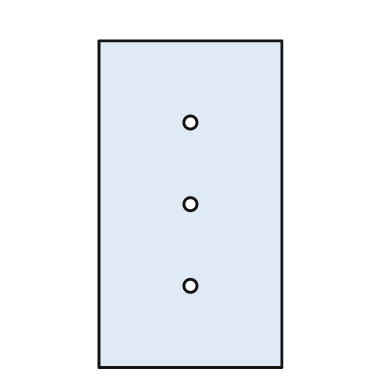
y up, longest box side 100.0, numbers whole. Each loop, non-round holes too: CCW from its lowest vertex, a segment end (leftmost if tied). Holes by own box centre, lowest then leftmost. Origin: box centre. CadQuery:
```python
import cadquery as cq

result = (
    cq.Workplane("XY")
    .moveTo(-28.0, -50.0)
    .lineTo(28.0, -50.0)
    .lineTo(28.0, 50.0)
    .lineTo(-28.0, 50.0)
    .close()
    .moveTo(0.0, -25.0)
    .circle(2.0)
    .moveTo(0.0, 0.0)
    .circle(2.0)
    .moveTo(0.0, 25.0)
    .circle(2.0)
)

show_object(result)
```